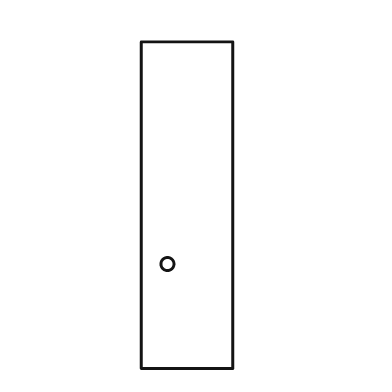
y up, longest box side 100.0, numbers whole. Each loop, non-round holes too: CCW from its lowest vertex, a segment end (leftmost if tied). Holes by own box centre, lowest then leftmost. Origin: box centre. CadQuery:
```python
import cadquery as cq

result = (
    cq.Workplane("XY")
    .moveTo(-14.0, -50.0)
    .lineTo(14.0, -50.0)
    .lineTo(14.0, 50.0)
    .lineTo(-14.0, 50.0)
    .close()
    .moveTo(-6.0, -18.0)
    .circle(2.0)
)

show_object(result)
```